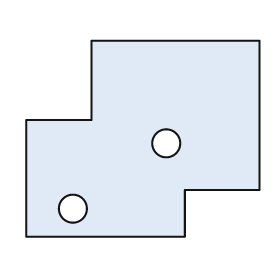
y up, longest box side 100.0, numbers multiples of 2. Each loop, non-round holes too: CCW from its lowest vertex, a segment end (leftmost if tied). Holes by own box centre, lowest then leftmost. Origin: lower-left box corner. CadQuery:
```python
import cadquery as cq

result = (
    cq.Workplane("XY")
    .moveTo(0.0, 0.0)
    .lineTo(68.0, 0.0)
    .lineTo(68.0, 20.0)
    .lineTo(100.0, 20.0)
    .lineTo(100.0, 84.0)
    .lineTo(28.0, 84.0)
    .lineTo(28.0, 50.0)
    .lineTo(0.0, 50.0)
    .close()
    .moveTo(20.0, 12.0)
    .circle(6.0)
    .moveTo(60.0, 40.0)
    .circle(6.0)
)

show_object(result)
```